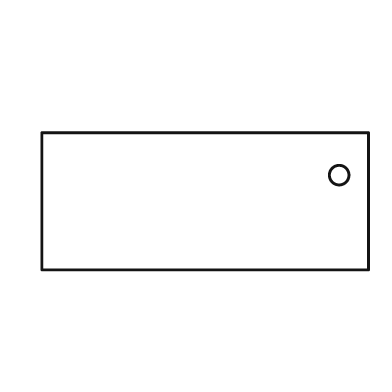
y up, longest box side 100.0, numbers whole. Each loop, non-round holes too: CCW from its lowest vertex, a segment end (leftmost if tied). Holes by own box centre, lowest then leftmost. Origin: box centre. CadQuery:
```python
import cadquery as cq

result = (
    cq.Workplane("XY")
    .moveTo(-50.0, -21.0)
    .lineTo(50.0, -21.0)
    .lineTo(50.0, 21.0)
    .lineTo(-50.0, 21.0)
    .close()
    .moveTo(41.0, 8.0)
    .circle(3.0)
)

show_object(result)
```